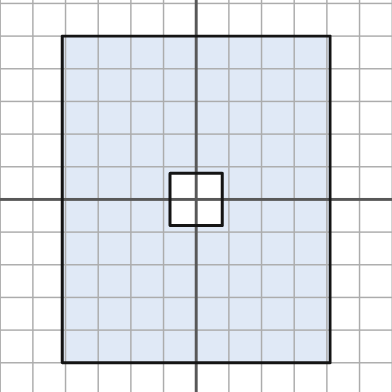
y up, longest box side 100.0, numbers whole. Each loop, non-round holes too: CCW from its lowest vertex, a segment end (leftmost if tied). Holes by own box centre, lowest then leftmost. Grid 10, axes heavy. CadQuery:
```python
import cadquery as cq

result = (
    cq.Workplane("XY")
    .moveTo(-41.0, -50.0)
    .lineTo(41.0, -50.0)
    .lineTo(41.0, 50.0)
    .lineTo(-41.0, 50.0)
    .close()
    .moveTo(-8.0, -8.0)
    .lineTo(8.0, -8.0)
    .lineTo(8.0, 8.0)
    .lineTo(-8.0, 8.0)
    .close()
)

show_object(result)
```